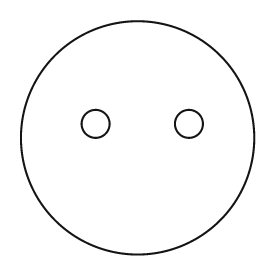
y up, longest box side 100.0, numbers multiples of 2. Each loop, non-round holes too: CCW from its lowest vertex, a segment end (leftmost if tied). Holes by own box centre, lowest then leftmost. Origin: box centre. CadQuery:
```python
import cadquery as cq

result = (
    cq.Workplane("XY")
    .moveTo(0.0, 0.0)
    .circle(50.0)
    .moveTo(-18.0, 6.0)
    .circle(6.0)
    .moveTo(22.0, 6.0)
    .circle(6.0)
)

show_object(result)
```